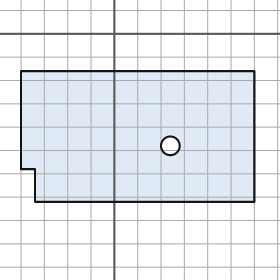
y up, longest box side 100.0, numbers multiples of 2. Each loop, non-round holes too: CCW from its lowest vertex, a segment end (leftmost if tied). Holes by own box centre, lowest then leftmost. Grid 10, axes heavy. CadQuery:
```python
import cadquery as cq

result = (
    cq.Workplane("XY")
    .moveTo(-34.0, -72.0)
    .lineTo(60.0, -72.0)
    .lineTo(60.0, -16.0)
    .lineTo(-40.0, -16.0)
    .lineTo(-40.0, -58.0)
    .lineTo(-34.0, -58.0)
    .close()
    .moveTo(24.0, -48.0)
    .circle(4.0)
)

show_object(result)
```